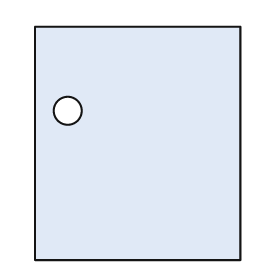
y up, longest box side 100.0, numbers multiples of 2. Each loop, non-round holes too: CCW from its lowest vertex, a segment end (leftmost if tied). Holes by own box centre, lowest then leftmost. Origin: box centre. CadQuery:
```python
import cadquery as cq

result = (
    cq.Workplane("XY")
    .moveTo(-44.0, -50.0)
    .lineTo(44.0, -50.0)
    .lineTo(44.0, 50.0)
    .lineTo(-44.0, 50.0)
    .close()
    .moveTo(-30.0, 14.0)
    .circle(6.0)
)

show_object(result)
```